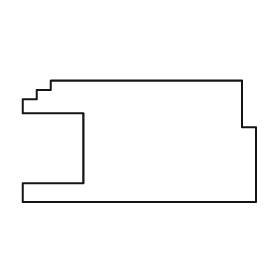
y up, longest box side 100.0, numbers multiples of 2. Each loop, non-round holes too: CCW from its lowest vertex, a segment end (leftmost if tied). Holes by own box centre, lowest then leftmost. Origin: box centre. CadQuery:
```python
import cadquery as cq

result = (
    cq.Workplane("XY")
    .moveTo(-50.0, -26.0)
    .lineTo(50.0, -26.0)
    .lineTo(50.0, 6.0)
    .lineTo(44.0, 6.0)
    .lineTo(44.0, 26.0)
    .lineTo(-38.0, 26.0)
    .lineTo(-38.0, 22.0)
    .lineTo(-44.0, 22.0)
    .lineTo(-44.0, 18.0)
    .lineTo(-50.0, 18.0)
    .lineTo(-50.0, 12.0)
    .lineTo(-24.0, 12.0)
    .lineTo(-24.0, -18.0)
    .lineTo(-50.0, -18.0)
    .close()
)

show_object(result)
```